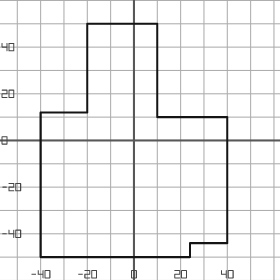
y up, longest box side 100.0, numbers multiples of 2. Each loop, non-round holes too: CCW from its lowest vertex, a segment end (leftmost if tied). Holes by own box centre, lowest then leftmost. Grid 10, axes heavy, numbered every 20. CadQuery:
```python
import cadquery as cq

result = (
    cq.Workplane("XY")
    .moveTo(-40.0, -50.0)
    .lineTo(24.0, -50.0)
    .lineTo(24.0, -44.0)
    .lineTo(40.0, -44.0)
    .lineTo(40.0, 10.0)
    .lineTo(10.0, 10.0)
    .lineTo(10.0, 50.0)
    .lineTo(-20.0, 50.0)
    .lineTo(-20.0, 12.0)
    .lineTo(-40.0, 12.0)
    .close()
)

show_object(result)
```